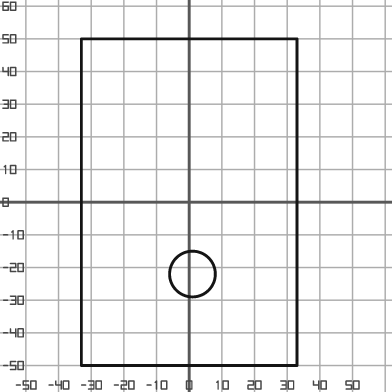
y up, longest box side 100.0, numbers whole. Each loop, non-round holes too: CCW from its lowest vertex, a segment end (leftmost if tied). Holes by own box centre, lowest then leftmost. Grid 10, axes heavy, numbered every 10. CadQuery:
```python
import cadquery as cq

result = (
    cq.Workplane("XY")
    .moveTo(-33.0, -50.0)
    .lineTo(33.0, -50.0)
    .lineTo(33.0, 50.0)
    .lineTo(-33.0, 50.0)
    .close()
    .moveTo(1.0, -22.0)
    .circle(7.0)
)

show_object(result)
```